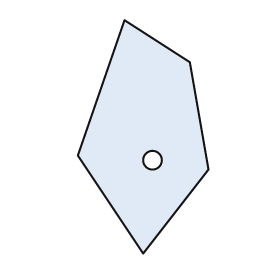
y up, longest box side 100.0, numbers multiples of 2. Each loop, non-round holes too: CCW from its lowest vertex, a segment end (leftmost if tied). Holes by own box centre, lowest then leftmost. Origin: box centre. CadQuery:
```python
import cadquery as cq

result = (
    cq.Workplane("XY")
    .moveTo(0.0, -50.0)
    .lineTo(28.0, -14.0)
    .lineTo(20.0, 32.0)
    .lineTo(-8.0, 50.0)
    .lineTo(-28.0, -8.0)
    .close()
    .moveTo(4.0, -10.0)
    .circle(4.0)
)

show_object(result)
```